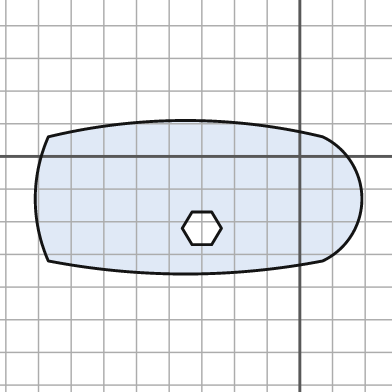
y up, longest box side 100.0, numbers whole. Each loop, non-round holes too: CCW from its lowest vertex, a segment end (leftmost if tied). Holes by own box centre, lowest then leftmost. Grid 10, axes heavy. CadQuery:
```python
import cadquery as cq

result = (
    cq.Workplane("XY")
    .moveTo(-77.0, -32.0)
    .threePointArc((-35.0, -36.0), (7.0, -32.0))
    .threePointArc((19.0, -13.0), (7.0, 6.0))
    .threePointArc((-35.0, 11.0), (-77.0, 6.0))
    .threePointArc((-81.0, -13.0), (-77.0, -32.0))
    .close()
    .moveTo(-33.0, -27.0)
    .lineTo(-27.0, -27.0)
    .lineTo(-24.0, -22.0)
    .lineTo(-27.0, -17.0)
    .lineTo(-33.0, -17.0)
    .lineTo(-36.0, -22.0)
    .close()
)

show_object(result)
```